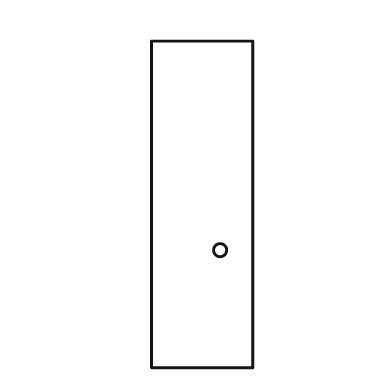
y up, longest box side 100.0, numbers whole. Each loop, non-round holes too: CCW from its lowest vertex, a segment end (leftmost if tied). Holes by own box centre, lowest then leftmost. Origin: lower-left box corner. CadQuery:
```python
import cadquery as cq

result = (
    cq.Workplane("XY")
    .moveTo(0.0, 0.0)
    .lineTo(31.0, 0.0)
    .lineTo(31.0, 100.0)
    .lineTo(0.0, 100.0)
    .close()
    .moveTo(21.0, 36.0)
    .circle(2.0)
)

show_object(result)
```